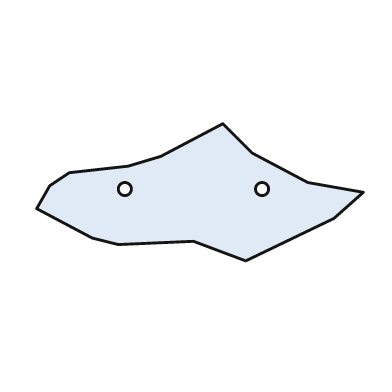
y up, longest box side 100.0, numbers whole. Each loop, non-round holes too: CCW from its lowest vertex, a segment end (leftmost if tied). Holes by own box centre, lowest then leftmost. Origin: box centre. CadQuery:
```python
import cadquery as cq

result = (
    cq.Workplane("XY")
    .moveTo(14.0, -21.0)
    .lineTo(41.0, -8.0)
    .lineTo(50.0, 0.0)
    .lineTo(33.0, 3.0)
    .lineTo(16.0, 12.0)
    .lineTo(7.0, 21.0)
    .lineTo(-12.0, 11.0)
    .lineTo(-22.0, 8.0)
    .lineTo(-40.0, 6.0)
    .lineTo(-46.0, 2.0)
    .lineTo(-50.0, -5.0)
    .lineTo(-33.0, -14.0)
    .lineTo(-25.0, -16.0)
    .lineTo(-2.0, -15.0)
    .close()
    .moveTo(-23.0, 1.0)
    .circle(2.0)
    .moveTo(19.0, 1.0)
    .circle(2.0)
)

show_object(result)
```